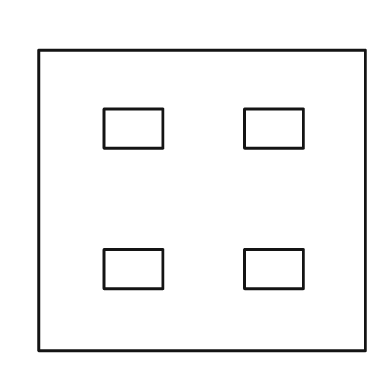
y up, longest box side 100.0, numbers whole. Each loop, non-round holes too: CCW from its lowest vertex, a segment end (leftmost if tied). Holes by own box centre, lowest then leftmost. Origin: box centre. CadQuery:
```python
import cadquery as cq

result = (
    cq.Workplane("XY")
    .moveTo(-50.0, -46.0)
    .lineTo(50.0, -46.0)
    .lineTo(50.0, 46.0)
    .lineTo(-50.0, 46.0)
    .close()
    .moveTo(-30.0, -27.0)
    .lineTo(-12.0, -27.0)
    .lineTo(-12.0, -15.0)
    .lineTo(-30.0, -15.0)
    .close()
    .moveTo(13.0, -27.0)
    .lineTo(31.0, -27.0)
    .lineTo(31.0, -15.0)
    .lineTo(13.0, -15.0)
    .close()
    .moveTo(-30.0, 16.0)
    .lineTo(-12.0, 16.0)
    .lineTo(-12.0, 28.0)
    .lineTo(-30.0, 28.0)
    .close()
    .moveTo(13.0, 16.0)
    .lineTo(31.0, 16.0)
    .lineTo(31.0, 28.0)
    .lineTo(13.0, 28.0)
    .close()
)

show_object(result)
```